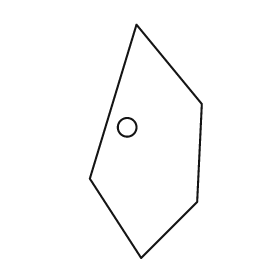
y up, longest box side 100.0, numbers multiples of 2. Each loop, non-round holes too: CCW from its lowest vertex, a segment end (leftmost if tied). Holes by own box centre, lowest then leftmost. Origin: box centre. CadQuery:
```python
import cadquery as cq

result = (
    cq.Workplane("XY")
    .moveTo(-2.0, -50.0)
    .lineTo(22.0, -26.0)
    .lineTo(24.0, 16.0)
    .lineTo(-4.0, 50.0)
    .lineTo(-24.0, -16.0)
    .close()
    .moveTo(-8.0, 6.0)
    .circle(4.0)
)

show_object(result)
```